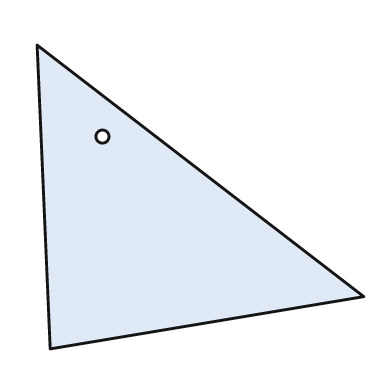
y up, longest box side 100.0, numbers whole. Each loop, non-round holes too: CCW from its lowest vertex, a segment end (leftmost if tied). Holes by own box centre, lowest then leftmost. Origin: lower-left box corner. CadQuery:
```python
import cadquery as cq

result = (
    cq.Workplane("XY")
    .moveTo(4.0, 0.0)
    .lineTo(100.0, 16.0)
    .lineTo(0.0, 93.0)
    .close()
    .moveTo(20.0, 65.0)
    .circle(2.0)
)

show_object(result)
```